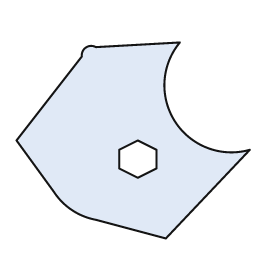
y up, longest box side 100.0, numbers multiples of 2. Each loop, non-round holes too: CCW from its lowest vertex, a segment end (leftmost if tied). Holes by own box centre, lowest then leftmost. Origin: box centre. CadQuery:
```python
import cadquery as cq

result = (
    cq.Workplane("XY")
    .moveTo(14.0, -42.0)
    .lineTo(50.0, -4.0)
    .threePointArc((18.0, 8.0), (20.0, 42.0))
    .lineTo(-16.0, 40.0)
    .threePointArc((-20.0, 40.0), (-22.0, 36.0))
    .lineTo(-50.0, 0.0)
    .lineTo(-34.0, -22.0)
    .threePointArc((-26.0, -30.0), (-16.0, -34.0))
    .close()
    .moveTo(2.0, -16.0)
    .lineTo(10.0, -12.0)
    .lineTo(10.0, -4.0)
    .lineTo(2.0, 0.0)
    .lineTo(-6.0, -4.0)
    .lineTo(-6.0, -12.0)
    .close()
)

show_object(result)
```